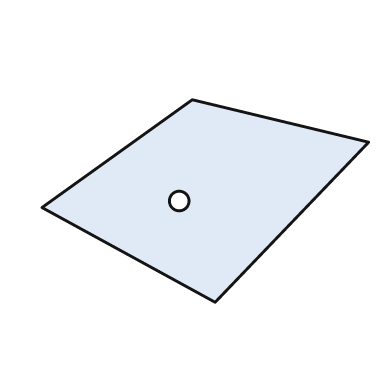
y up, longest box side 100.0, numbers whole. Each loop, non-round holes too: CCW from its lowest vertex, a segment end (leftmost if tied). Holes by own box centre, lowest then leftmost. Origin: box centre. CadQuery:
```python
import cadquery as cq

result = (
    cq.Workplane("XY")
    .moveTo(3.0, -31.0)
    .lineTo(50.0, 18.0)
    .lineTo(-4.0, 31.0)
    .lineTo(-50.0, -2.0)
    .close()
    .moveTo(-8.0, 0.0)
    .circle(3.0)
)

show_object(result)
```